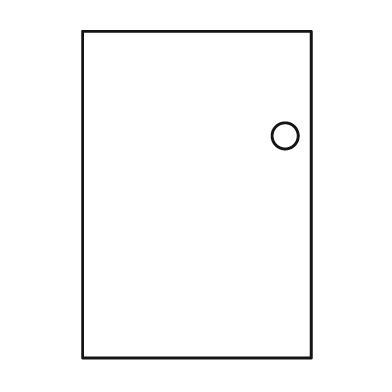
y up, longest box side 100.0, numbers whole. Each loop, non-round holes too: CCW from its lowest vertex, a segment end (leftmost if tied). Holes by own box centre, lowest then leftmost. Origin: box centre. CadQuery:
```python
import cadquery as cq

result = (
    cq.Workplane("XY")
    .moveTo(-35.0, -50.0)
    .lineTo(35.0, -50.0)
    .lineTo(35.0, 50.0)
    .lineTo(-35.0, 50.0)
    .close()
    .moveTo(27.0, 18.0)
    .circle(4.0)
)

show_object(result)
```